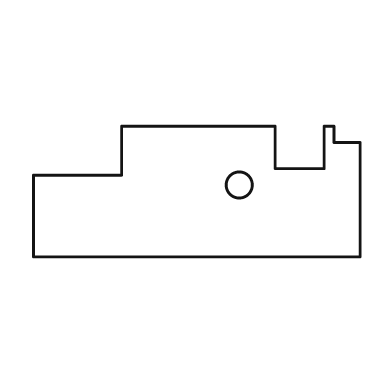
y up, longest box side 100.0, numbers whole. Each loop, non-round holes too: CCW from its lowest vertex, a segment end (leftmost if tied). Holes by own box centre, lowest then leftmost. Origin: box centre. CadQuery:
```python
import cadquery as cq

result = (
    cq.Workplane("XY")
    .moveTo(-50.0, -20.0)
    .lineTo(50.0, -20.0)
    .lineTo(50.0, 15.0)
    .lineTo(42.0, 15.0)
    .lineTo(42.0, 20.0)
    .lineTo(39.0, 20.0)
    .lineTo(39.0, 7.0)
    .lineTo(24.0, 7.0)
    .lineTo(24.0, 20.0)
    .lineTo(-23.0, 20.0)
    .lineTo(-23.0, 5.0)
    .lineTo(-50.0, 5.0)
    .close()
    .moveTo(13.0, 2.0)
    .circle(4.0)
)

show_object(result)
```